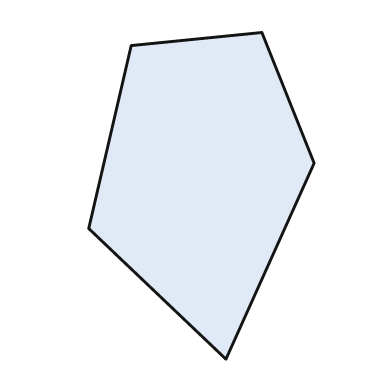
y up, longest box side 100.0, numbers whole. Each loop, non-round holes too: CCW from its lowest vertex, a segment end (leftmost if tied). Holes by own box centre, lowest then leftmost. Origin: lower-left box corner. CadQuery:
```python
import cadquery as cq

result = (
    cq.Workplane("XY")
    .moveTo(42.0, 0.0)
    .lineTo(69.0, 60.0)
    .lineTo(53.0, 100.0)
    .lineTo(13.0, 96.0)
    .lineTo(0.0, 40.0)
    .close()
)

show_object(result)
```